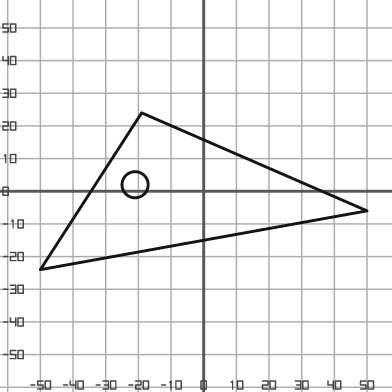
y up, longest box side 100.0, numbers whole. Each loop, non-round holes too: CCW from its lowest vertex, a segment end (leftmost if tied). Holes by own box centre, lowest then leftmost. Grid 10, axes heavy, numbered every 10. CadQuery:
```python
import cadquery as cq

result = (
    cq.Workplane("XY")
    .moveTo(-50.0, -24.0)
    .lineTo(50.0, -6.0)
    .lineTo(-19.0, 24.0)
    .close()
    .moveTo(-21.0, 2.0)
    .circle(4.0)
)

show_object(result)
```